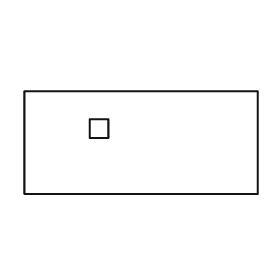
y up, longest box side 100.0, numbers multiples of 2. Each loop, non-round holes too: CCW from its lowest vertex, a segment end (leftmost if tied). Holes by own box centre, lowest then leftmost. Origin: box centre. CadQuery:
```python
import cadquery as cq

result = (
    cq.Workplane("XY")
    .moveTo(-50.0, -22.0)
    .lineTo(50.0, -22.0)
    .lineTo(50.0, 22.0)
    .lineTo(-50.0, 22.0)
    .close()
    .moveTo(-22.0, 2.0)
    .lineTo(-14.0, 2.0)
    .lineTo(-14.0, 10.0)
    .lineTo(-22.0, 10.0)
    .close()
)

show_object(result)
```